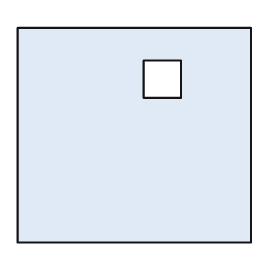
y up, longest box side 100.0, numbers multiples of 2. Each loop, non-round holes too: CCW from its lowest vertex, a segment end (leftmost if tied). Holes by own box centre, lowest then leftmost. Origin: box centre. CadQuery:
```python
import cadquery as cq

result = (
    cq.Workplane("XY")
    .moveTo(-50.0, -46.0)
    .lineTo(50.0, -46.0)
    .lineTo(50.0, 46.0)
    .lineTo(-50.0, 46.0)
    .close()
    .moveTo(4.0, 16.0)
    .lineTo(20.0, 16.0)
    .lineTo(20.0, 32.0)
    .lineTo(4.0, 32.0)
    .close()
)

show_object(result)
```